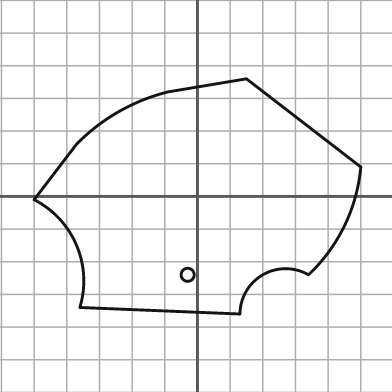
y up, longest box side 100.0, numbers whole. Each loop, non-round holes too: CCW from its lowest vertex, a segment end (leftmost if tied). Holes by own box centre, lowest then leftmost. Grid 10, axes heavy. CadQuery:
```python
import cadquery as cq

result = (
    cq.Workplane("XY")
    .moveTo(13.0, -36.0)
    .threePointArc((20.0, -24.0), (34.0, -24.0))
    .threePointArc((45.0, -9.0), (50.0, 9.0))
    .lineTo(15.0, 36.0)
    .lineTo(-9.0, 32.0)
    .threePointArc((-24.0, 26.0), (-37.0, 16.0))
    .lineTo(-50.0, -1.0)
    .threePointArc((-37.0, -15.0), (-36.0, -34.0))
    .close()
    .moveTo(-3.0, -24.0)
    .circle(2.0)
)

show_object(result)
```